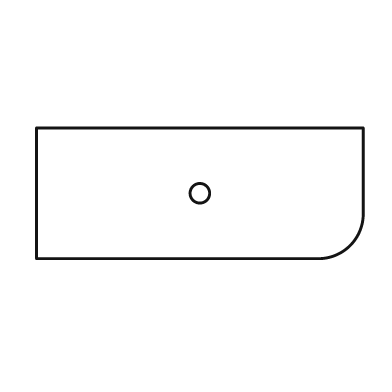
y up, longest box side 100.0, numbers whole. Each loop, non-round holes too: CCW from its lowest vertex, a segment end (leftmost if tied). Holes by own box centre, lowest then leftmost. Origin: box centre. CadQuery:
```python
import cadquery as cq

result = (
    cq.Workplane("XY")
    .moveTo(-50.0, -20.0)
    .lineTo(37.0, -20.0)
    .threePointArc((46.0, -16.0), (50.0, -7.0))
    .lineTo(50.0, 20.0)
    .lineTo(-50.0, 20.0)
    .close()
    .moveTo(0.0, 0.0)
    .circle(3.0)
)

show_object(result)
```